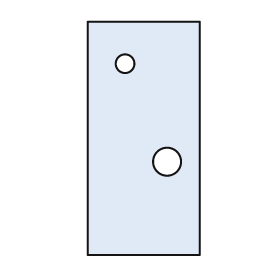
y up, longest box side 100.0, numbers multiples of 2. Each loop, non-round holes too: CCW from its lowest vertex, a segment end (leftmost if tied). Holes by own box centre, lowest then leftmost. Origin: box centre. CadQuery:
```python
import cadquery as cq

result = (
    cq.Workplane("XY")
    .moveTo(-24.0, -50.0)
    .lineTo(24.0, -50.0)
    .lineTo(24.0, 50.0)
    .lineTo(-24.0, 50.0)
    .close()
    .moveTo(10.0, -10.0)
    .circle(6.0)
    .moveTo(-8.0, 32.0)
    .circle(4.0)
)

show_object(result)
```